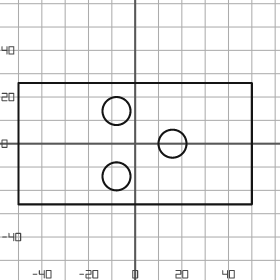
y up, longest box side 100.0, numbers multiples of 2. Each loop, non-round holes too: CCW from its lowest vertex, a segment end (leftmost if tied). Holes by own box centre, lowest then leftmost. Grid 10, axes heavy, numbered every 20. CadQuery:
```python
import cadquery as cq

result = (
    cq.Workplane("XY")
    .moveTo(-50.0, -26.0)
    .lineTo(50.0, -26.0)
    .lineTo(50.0, 26.0)
    .lineTo(-50.0, 26.0)
    .close()
    .moveTo(-8.0, -14.0)
    .circle(6.0)
    .moveTo(16.0, 0.0)
    .circle(6.0)
    .moveTo(-8.0, 14.0)
    .circle(6.0)
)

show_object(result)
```